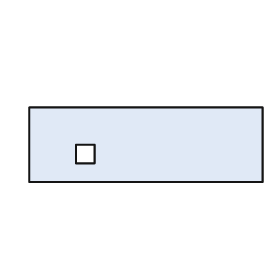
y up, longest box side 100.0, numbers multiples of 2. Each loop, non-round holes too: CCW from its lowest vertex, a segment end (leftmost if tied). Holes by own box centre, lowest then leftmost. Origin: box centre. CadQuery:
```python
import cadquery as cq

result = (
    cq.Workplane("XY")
    .moveTo(-50.0, -16.0)
    .lineTo(50.0, -16.0)
    .lineTo(50.0, 16.0)
    .lineTo(-50.0, 16.0)
    .close()
    .moveTo(-30.0, -8.0)
    .lineTo(-22.0, -8.0)
    .lineTo(-22.0, 0.0)
    .lineTo(-30.0, 0.0)
    .close()
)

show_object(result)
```